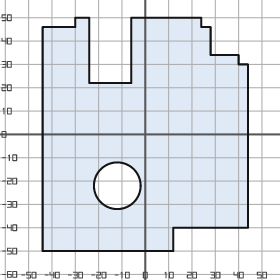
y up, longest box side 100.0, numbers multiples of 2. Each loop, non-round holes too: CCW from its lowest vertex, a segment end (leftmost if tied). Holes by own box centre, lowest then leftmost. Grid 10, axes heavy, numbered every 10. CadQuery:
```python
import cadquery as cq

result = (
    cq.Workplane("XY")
    .moveTo(-44.0, -50.0)
    .lineTo(12.0, -50.0)
    .lineTo(12.0, -40.0)
    .lineTo(44.0, -40.0)
    .lineTo(44.0, 30.0)
    .lineTo(40.0, 30.0)
    .lineTo(40.0, 34.0)
    .lineTo(28.0, 34.0)
    .lineTo(28.0, 46.0)
    .lineTo(24.0, 46.0)
    .lineTo(24.0, 50.0)
    .lineTo(-6.0, 50.0)
    .lineTo(-6.0, 22.0)
    .lineTo(-24.0, 22.0)
    .lineTo(-24.0, 50.0)
    .lineTo(-30.0, 50.0)
    .lineTo(-30.0, 46.0)
    .lineTo(-44.0, 46.0)
    .close()
    .moveTo(-12.0, -22.0)
    .circle(10.0)
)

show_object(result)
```